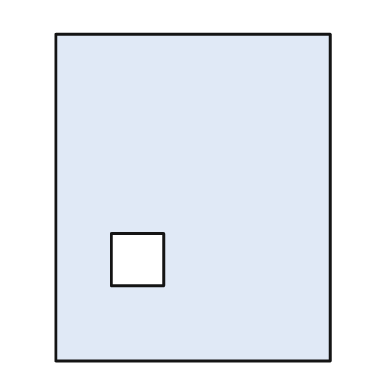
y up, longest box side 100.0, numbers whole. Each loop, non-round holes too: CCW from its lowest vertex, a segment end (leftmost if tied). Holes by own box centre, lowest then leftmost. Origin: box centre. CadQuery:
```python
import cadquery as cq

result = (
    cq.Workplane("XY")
    .moveTo(-42.0, -50.0)
    .lineTo(42.0, -50.0)
    .lineTo(42.0, 50.0)
    .lineTo(-42.0, 50.0)
    .close()
    .moveTo(-25.0, -27.0)
    .lineTo(-9.0, -27.0)
    .lineTo(-9.0, -11.0)
    .lineTo(-25.0, -11.0)
    .close()
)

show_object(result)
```